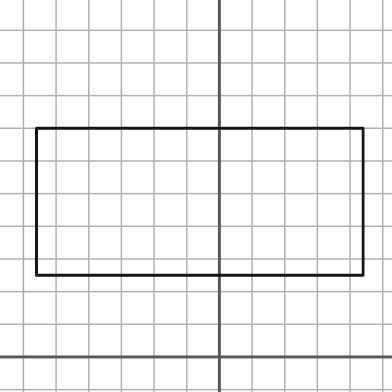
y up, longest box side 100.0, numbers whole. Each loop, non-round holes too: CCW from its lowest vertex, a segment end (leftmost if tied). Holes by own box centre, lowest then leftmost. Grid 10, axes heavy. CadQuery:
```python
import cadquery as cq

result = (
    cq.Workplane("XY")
    .moveTo(-56.0, 25.0)
    .lineTo(44.0, 25.0)
    .lineTo(44.0, 70.0)
    .lineTo(-56.0, 70.0)
    .close()
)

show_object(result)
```